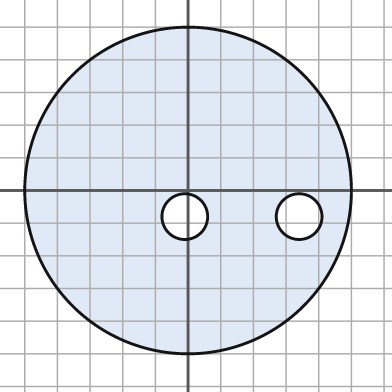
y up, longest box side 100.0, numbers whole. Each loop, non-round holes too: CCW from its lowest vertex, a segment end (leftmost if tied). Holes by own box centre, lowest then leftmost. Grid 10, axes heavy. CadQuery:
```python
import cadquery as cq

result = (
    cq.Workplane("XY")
    .moveTo(0.0, 0.0)
    .circle(50.0)
    .moveTo(-1.0, -8.0)
    .circle(7.0)
    .moveTo(34.0, -8.0)
    .circle(7.0)
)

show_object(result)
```